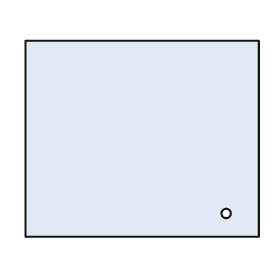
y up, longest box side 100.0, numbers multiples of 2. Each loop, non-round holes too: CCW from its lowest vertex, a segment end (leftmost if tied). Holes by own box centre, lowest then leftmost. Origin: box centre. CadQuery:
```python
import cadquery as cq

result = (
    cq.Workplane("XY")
    .moveTo(-50.0, -42.0)
    .lineTo(50.0, -42.0)
    .lineTo(50.0, 42.0)
    .lineTo(-50.0, 42.0)
    .close()
    .moveTo(36.0, -32.0)
    .circle(2.0)
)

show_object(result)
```